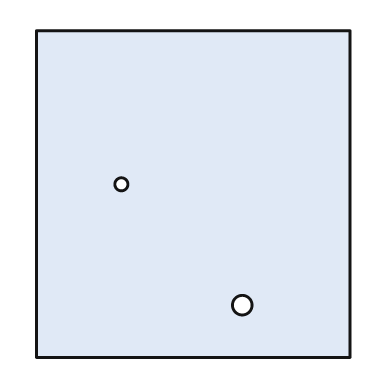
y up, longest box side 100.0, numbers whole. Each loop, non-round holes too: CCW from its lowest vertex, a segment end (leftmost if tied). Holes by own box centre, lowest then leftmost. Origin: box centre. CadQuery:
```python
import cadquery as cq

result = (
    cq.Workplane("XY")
    .moveTo(-48.0, -50.0)
    .lineTo(48.0, -50.0)
    .lineTo(48.0, 50.0)
    .lineTo(-48.0, 50.0)
    .close()
    .moveTo(15.0, -34.0)
    .circle(3.0)
    .moveTo(-22.0, 3.0)
    .circle(2.0)
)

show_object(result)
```